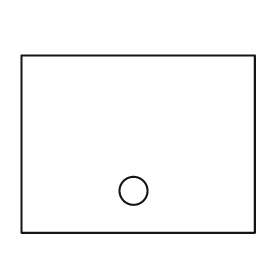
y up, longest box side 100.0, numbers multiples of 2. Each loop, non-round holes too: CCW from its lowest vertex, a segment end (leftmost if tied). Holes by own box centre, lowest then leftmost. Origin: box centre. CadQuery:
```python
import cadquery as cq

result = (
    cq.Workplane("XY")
    .moveTo(-50.0, -38.0)
    .lineTo(50.0, -38.0)
    .lineTo(50.0, 38.0)
    .lineTo(-50.0, 38.0)
    .close()
    .moveTo(-2.0, -20.0)
    .circle(6.0)
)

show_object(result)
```